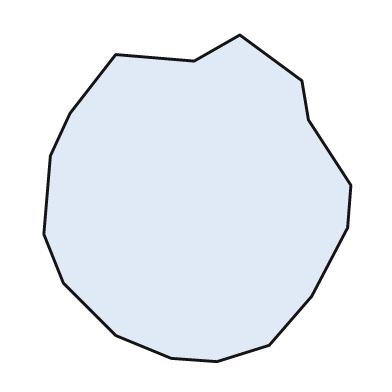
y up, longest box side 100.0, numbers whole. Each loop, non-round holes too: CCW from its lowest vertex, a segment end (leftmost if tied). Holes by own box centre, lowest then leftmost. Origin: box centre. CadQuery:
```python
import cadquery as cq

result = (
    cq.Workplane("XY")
    .moveTo(6.0, -50.0)
    .lineTo(22.0, -45.0)
    .lineTo(35.0, -30.0)
    .lineTo(46.0, -9.0)
    .lineTo(47.0, 4.0)
    .lineTo(34.0, 24.0)
    .lineTo(32.0, 36.0)
    .lineTo(13.0, 50.0)
    .lineTo(-1.0, 42.0)
    .lineTo(-25.0, 44.0)
    .lineTo(-39.0, 26.0)
    .lineTo(-45.0, 13.0)
    .lineTo(-47.0, -11.0)
    .lineTo(-41.0, -26.0)
    .lineTo(-25.0, -42.0)
    .lineTo(-8.0, -49.0)
    .close()
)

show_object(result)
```